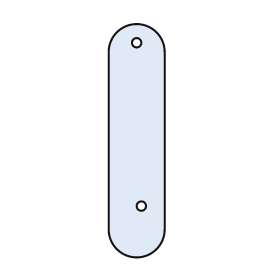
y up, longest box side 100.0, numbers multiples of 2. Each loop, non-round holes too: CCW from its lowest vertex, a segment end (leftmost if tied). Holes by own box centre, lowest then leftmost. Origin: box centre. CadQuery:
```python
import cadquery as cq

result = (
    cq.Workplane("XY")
    .moveTo(-12.0, -38.0)
    .threePointArc((0.0, -50.0), (12.0, -38.0))
    .lineTo(12.0, 38.0)
    .threePointArc((0.0, 50.0), (-12.0, 38.0))
    .close()
    .moveTo(2.0, -28.0)
    .circle(2.0)
    .moveTo(0.0, 42.0)
    .circle(2.0)
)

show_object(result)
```